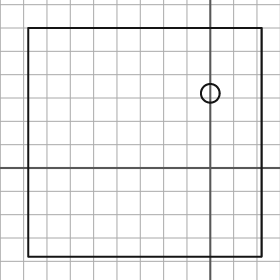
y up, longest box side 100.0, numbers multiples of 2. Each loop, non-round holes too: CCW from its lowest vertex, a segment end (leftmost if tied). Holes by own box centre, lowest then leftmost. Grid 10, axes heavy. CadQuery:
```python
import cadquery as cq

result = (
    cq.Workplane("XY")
    .moveTo(-78.0, -38.0)
    .lineTo(22.0, -38.0)
    .lineTo(22.0, 60.0)
    .lineTo(-78.0, 60.0)
    .close()
    .moveTo(0.0, 32.0)
    .circle(4.0)
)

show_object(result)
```